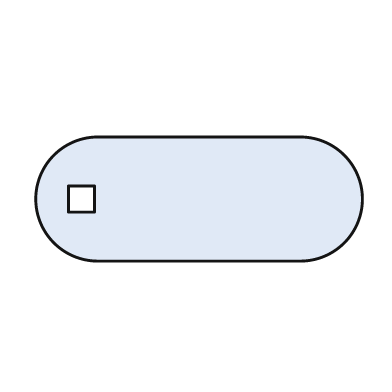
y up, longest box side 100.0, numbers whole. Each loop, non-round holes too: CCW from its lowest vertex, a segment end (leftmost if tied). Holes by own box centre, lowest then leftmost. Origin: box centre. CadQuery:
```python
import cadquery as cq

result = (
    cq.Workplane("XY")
    .moveTo(-31.0, -19.0)
    .lineTo(31.0, -19.0)
    .threePointArc((50.0, 0.0), (31.0, 19.0))
    .lineTo(-31.0, 19.0)
    .threePointArc((-50.0, 0.0), (-31.0, -19.0))
    .close()
    .moveTo(-40.0, -4.0)
    .lineTo(-32.0, -4.0)
    .lineTo(-32.0, 4.0)
    .lineTo(-40.0, 4.0)
    .close()
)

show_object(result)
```